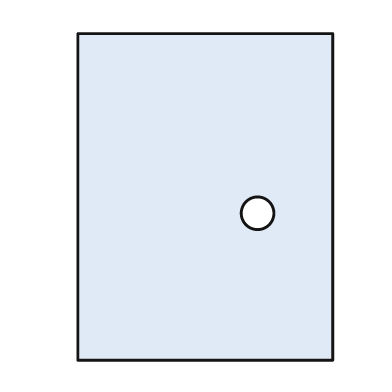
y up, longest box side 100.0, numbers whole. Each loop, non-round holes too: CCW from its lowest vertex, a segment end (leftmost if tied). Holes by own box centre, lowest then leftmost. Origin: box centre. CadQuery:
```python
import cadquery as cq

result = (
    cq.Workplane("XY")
    .moveTo(-39.0, -50.0)
    .lineTo(39.0, -50.0)
    .lineTo(39.0, 50.0)
    .lineTo(-39.0, 50.0)
    .close()
    .moveTo(16.0, -5.0)
    .circle(5.0)
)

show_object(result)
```